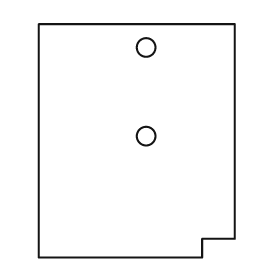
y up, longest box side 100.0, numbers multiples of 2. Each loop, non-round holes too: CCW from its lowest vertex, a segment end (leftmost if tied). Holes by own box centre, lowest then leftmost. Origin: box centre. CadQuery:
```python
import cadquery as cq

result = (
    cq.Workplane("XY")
    .moveTo(-42.0, -50.0)
    .lineTo(28.0, -50.0)
    .lineTo(28.0, -42.0)
    .lineTo(42.0, -42.0)
    .lineTo(42.0, 50.0)
    .lineTo(-42.0, 50.0)
    .close()
    .moveTo(4.0, 2.0)
    .circle(4.0)
    .moveTo(4.0, 40.0)
    .circle(4.0)
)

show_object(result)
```